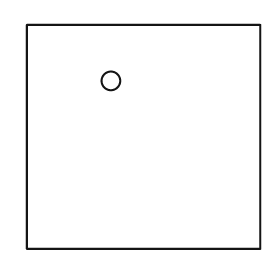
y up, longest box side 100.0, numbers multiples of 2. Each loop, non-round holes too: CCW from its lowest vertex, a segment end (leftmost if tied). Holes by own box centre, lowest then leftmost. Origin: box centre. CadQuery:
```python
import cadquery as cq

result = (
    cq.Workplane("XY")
    .moveTo(-50.0, -48.0)
    .lineTo(50.0, -48.0)
    .lineTo(50.0, 48.0)
    .lineTo(-50.0, 48.0)
    .close()
    .moveTo(-14.0, 24.0)
    .circle(4.0)
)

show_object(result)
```